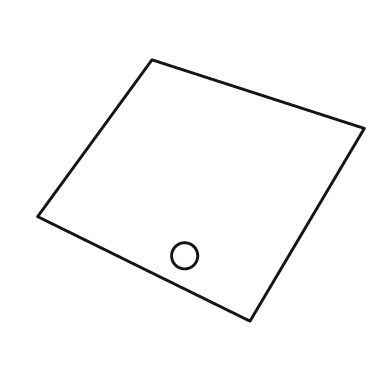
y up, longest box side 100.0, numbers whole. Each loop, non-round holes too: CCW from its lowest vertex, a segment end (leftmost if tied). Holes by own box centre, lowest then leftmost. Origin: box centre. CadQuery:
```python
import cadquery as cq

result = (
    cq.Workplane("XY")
    .moveTo(15.0, -40.0)
    .lineTo(50.0, 19.0)
    .lineTo(-15.0, 40.0)
    .lineTo(-50.0, -8.0)
    .close()
    .moveTo(-5.0, -20.0)
    .circle(4.0)
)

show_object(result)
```